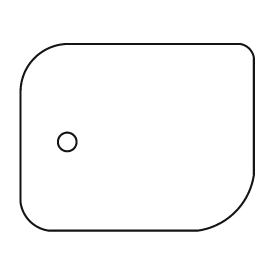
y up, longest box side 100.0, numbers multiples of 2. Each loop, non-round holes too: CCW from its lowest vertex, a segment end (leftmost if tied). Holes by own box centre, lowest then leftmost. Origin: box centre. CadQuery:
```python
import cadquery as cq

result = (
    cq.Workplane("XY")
    .moveTo(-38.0, -40.0)
    .lineTo(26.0, -40.0)
    .threePointArc((42.0, -32.0), (50.0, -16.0))
    .lineTo(50.0, 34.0)
    .threePointArc((48.0, 38.0), (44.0, 40.0))
    .lineTo(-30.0, 40.0)
    .threePointArc((-44.0, 34.0), (-50.0, 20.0))
    .lineTo(-50.0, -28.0)
    .threePointArc((-46.0, -36.0), (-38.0, -40.0))
    .close()
    .moveTo(-30.0, -2.0)
    .circle(4.0)
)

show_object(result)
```